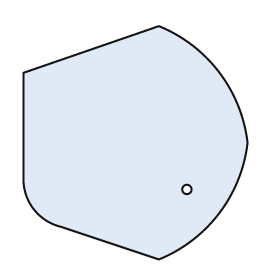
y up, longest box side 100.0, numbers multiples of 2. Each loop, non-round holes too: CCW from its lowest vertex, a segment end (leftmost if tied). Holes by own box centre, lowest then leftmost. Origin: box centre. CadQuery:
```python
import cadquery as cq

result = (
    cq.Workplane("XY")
    .moveTo(10.0, -50.0)
    .threePointArc((36.0, -30.0), (48.0, 0.0))
    .threePointArc((36.0, 30.0), (10.0, 50.0))
    .lineTo(-48.0, 30.0)
    .lineTo(-48.0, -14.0)
    .threePointArc((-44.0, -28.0), (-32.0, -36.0))
    .close()
    .moveTo(22.0, -20.0)
    .circle(2.0)
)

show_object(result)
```